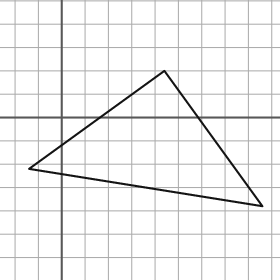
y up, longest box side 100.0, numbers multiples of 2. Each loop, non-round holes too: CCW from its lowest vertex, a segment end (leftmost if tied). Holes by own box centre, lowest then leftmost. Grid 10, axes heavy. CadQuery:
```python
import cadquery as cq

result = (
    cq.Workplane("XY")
    .moveTo(86.0, -38.0)
    .lineTo(44.0, 20.0)
    .lineTo(-14.0, -22.0)
    .close()
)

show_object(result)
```